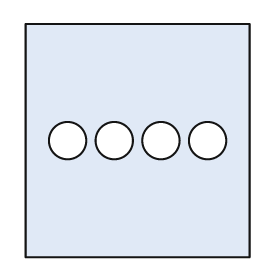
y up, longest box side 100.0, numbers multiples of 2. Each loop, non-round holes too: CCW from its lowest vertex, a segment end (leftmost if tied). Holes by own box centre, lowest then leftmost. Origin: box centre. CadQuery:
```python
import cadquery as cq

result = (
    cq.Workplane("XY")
    .moveTo(-48.0, -50.0)
    .lineTo(48.0, -50.0)
    .lineTo(48.0, 50.0)
    .lineTo(-48.0, 50.0)
    .close()
    .moveTo(-30.0, 0.0)
    .circle(8.0)
    .moveTo(-10.0, 0.0)
    .circle(8.0)
    .moveTo(10.0, 0.0)
    .circle(8.0)
    .moveTo(30.0, 0.0)
    .circle(8.0)
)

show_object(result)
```